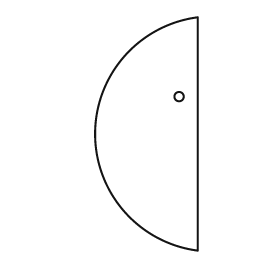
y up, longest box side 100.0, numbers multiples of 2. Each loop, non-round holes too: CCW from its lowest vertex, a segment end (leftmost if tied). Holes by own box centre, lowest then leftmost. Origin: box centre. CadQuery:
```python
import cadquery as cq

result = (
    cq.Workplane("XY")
    .moveTo(22.0, -50.0)
    .lineTo(22.0, 50.0)
    .threePointArc((-22.0, 0.0), (22.0, -50.0))
    .close()
    .moveTo(14.0, 16.0)
    .circle(2.0)
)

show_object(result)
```